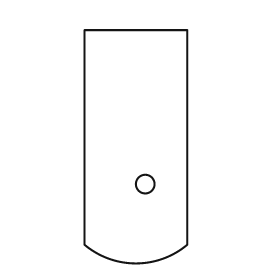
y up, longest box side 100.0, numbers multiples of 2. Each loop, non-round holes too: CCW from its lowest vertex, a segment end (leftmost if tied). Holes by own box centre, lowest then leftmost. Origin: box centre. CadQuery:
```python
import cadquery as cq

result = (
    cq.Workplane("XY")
    .moveTo(-22.0, -42.0)
    .threePointArc((0.0, -50.0), (22.0, -42.0))
    .lineTo(22.0, 50.0)
    .lineTo(-22.0, 50.0)
    .close()
    .moveTo(4.0, -16.0)
    .circle(4.0)
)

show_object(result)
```